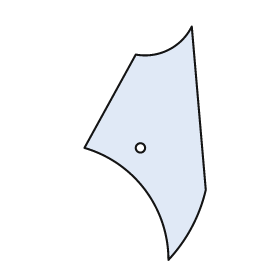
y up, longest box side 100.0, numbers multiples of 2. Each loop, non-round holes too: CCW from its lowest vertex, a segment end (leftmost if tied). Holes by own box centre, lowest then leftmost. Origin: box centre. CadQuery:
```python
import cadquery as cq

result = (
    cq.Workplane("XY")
    .moveTo(10.0, -50.0)
    .threePointArc((20.0, -36.0), (26.0, -20.0))
    .lineTo(20.0, 50.0)
    .threePointArc((10.0, 40.0), (-4.0, 38.0))
    .lineTo(-26.0, -2.0)
    .threePointArc((0.0, -20.0), (10.0, -50.0))
    .close()
    .moveTo(-2.0, -2.0)
    .circle(2.0)
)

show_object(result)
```